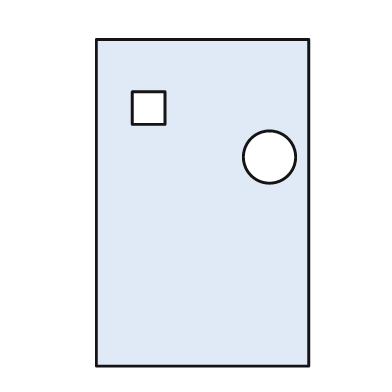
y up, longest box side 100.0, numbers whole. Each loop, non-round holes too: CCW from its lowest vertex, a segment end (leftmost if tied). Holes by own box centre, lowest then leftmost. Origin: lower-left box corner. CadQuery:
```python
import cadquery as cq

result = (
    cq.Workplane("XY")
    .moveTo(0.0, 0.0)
    .lineTo(65.0, 0.0)
    .lineTo(65.0, 100.0)
    .lineTo(0.0, 100.0)
    .close()
    .moveTo(53.0, 64.0)
    .circle(8.0)
    .moveTo(11.0, 74.0)
    .lineTo(21.0, 74.0)
    .lineTo(21.0, 84.0)
    .lineTo(11.0, 84.0)
    .close()
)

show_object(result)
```